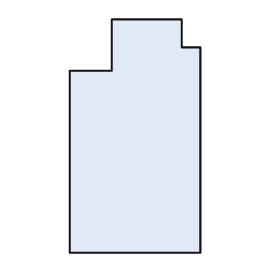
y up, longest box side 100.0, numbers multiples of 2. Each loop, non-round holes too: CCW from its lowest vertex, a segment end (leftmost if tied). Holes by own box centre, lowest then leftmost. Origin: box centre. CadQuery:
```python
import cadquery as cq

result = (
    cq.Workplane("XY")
    .moveTo(-28.0, -50.0)
    .lineTo(28.0, -50.0)
    .lineTo(28.0, 38.0)
    .lineTo(20.0, 38.0)
    .lineTo(20.0, 50.0)
    .lineTo(-10.0, 50.0)
    .lineTo(-10.0, 28.0)
    .lineTo(-28.0, 28.0)
    .close()
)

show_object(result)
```